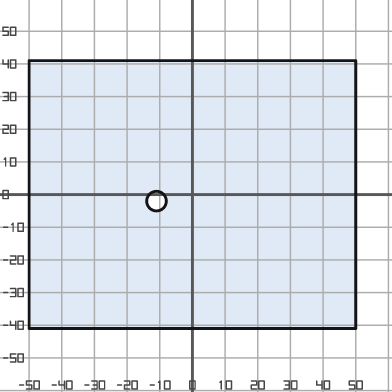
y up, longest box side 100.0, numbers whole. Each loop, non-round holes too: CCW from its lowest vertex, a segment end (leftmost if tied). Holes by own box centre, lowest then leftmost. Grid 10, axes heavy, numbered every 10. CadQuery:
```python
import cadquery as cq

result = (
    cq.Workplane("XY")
    .moveTo(-50.0, -41.0)
    .lineTo(50.0, -41.0)
    .lineTo(50.0, 41.0)
    .lineTo(-50.0, 41.0)
    .close()
    .moveTo(-11.0, -2.0)
    .circle(3.0)
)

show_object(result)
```